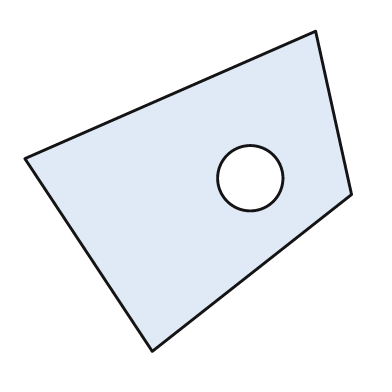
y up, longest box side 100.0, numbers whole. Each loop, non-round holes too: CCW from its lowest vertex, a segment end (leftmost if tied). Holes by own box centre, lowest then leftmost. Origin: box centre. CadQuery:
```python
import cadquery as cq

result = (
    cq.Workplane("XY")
    .moveTo(-11.0, -49.0)
    .lineTo(50.0, -1.0)
    .lineTo(39.0, 49.0)
    .lineTo(-50.0, 10.0)
    .close()
    .moveTo(19.0, 4.0)
    .circle(10.0)
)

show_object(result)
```